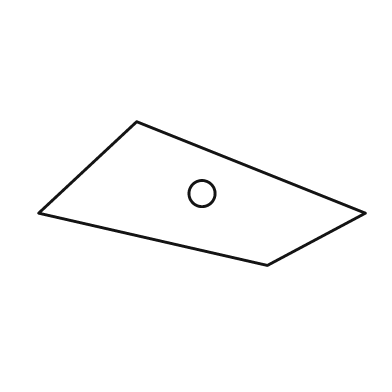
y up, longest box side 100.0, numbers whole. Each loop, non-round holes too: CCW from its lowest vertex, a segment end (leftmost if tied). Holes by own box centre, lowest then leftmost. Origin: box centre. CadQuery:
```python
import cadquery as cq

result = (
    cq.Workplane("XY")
    .moveTo(20.0, -22.0)
    .lineTo(50.0, -6.0)
    .lineTo(-20.0, 22.0)
    .lineTo(-50.0, -6.0)
    .close()
    .moveTo(0.0, 0.0)
    .circle(4.0)
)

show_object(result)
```